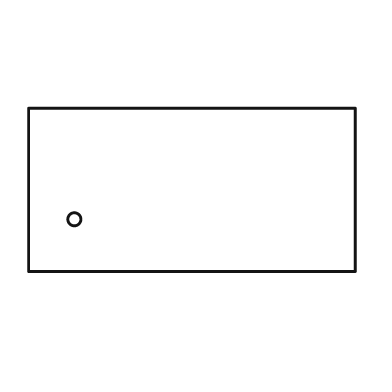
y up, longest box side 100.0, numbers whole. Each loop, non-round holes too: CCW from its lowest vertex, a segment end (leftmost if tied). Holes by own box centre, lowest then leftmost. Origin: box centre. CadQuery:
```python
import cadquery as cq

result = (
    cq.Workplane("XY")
    .moveTo(-50.0, -25.0)
    .lineTo(50.0, -25.0)
    .lineTo(50.0, 25.0)
    .lineTo(-50.0, 25.0)
    .close()
    .moveTo(-36.0, -9.0)
    .circle(2.0)
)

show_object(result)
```